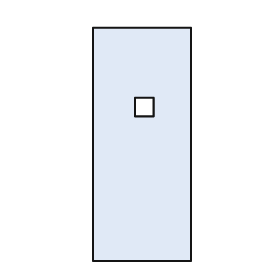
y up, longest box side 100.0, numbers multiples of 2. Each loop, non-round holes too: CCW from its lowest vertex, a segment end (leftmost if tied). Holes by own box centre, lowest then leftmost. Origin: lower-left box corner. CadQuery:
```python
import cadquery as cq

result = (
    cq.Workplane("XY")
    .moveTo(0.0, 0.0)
    .lineTo(42.0, 0.0)
    .lineTo(42.0, 100.0)
    .lineTo(0.0, 100.0)
    .close()
    .moveTo(18.0, 62.0)
    .lineTo(26.0, 62.0)
    .lineTo(26.0, 70.0)
    .lineTo(18.0, 70.0)
    .close()
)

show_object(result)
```